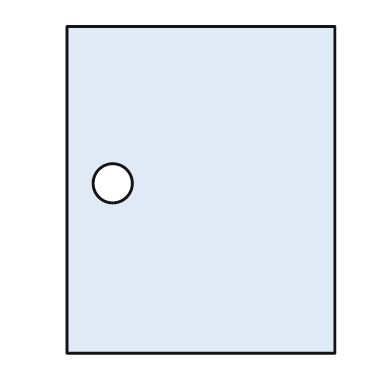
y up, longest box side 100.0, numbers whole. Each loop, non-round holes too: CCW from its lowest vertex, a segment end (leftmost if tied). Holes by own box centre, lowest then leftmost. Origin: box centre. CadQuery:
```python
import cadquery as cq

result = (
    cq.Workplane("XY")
    .moveTo(-41.0, -50.0)
    .lineTo(41.0, -50.0)
    .lineTo(41.0, 50.0)
    .lineTo(-41.0, 50.0)
    .close()
    .moveTo(-27.0, 2.0)
    .circle(6.0)
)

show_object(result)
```